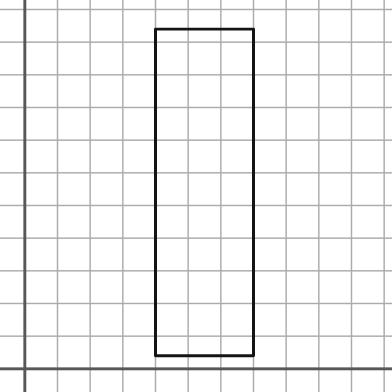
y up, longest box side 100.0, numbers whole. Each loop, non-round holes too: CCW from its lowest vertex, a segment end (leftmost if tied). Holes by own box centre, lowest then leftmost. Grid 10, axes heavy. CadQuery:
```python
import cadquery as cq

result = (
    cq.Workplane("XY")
    .moveTo(40.0, 4.0)
    .lineTo(70.0, 4.0)
    .lineTo(70.0, 104.0)
    .lineTo(40.0, 104.0)
    .close()
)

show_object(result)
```